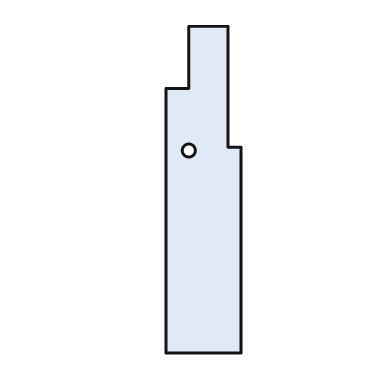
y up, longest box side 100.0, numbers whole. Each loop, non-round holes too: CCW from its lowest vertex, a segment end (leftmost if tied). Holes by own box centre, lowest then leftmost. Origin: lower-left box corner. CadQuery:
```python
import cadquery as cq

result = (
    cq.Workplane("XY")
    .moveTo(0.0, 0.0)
    .lineTo(23.0, 0.0)
    .lineTo(23.0, 63.0)
    .lineTo(19.0, 63.0)
    .lineTo(19.0, 100.0)
    .lineTo(7.0, 100.0)
    .lineTo(7.0, 81.0)
    .lineTo(0.0, 81.0)
    .close()
    .moveTo(7.0, 62.0)
    .circle(2.0)
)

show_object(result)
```